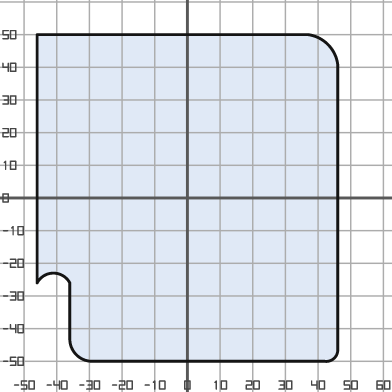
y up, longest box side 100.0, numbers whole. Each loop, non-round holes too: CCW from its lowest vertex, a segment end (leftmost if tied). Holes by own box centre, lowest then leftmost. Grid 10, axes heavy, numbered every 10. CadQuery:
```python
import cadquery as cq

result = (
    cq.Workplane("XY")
    .moveTo(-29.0, -50.0)
    .lineTo(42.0, -50.0)
    .threePointArc((45.0, -49.0), (46.0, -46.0))
    .lineTo(46.0, 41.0)
    .threePointArc((43.0, 47.0), (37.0, 50.0))
    .lineTo(-46.0, 50.0)
    .lineTo(-46.0, -26.0)
    .threePointArc((-41.0, -23.0), (-36.0, -26.0))
    .lineTo(-36.0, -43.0)
    .threePointArc((-34.0, -48.0), (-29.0, -50.0))
    .close()
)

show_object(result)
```